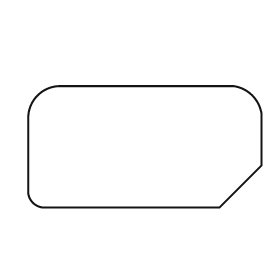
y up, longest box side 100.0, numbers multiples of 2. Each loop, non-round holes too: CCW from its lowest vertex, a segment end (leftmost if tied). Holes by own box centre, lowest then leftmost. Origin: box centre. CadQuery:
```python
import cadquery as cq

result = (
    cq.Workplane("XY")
    .moveTo(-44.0, -26.0)
    .lineTo(32.0, -26.0)
    .lineTo(50.0, -8.0)
    .lineTo(50.0, 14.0)
    .threePointArc((46.0, 22.0), (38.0, 26.0))
    .lineTo(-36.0, 26.0)
    .threePointArc((-46.0, 22.0), (-50.0, 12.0))
    .lineTo(-50.0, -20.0)
    .threePointArc((-48.0, -24.0), (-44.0, -26.0))
    .close()
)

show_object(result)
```